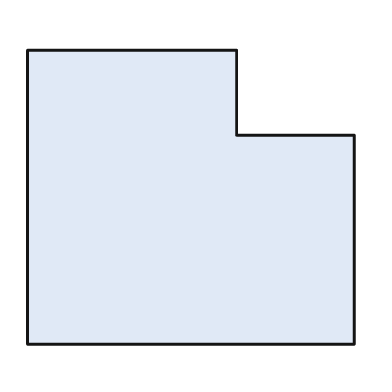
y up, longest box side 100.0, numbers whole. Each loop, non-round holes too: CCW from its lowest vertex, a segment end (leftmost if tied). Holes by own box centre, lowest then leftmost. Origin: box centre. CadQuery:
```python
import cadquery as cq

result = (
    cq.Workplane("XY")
    .moveTo(-50.0, -45.0)
    .lineTo(50.0, -45.0)
    .lineTo(50.0, 19.0)
    .lineTo(14.0, 19.0)
    .lineTo(14.0, 45.0)
    .lineTo(-50.0, 45.0)
    .close()
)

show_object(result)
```